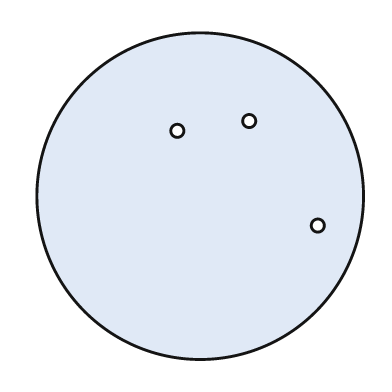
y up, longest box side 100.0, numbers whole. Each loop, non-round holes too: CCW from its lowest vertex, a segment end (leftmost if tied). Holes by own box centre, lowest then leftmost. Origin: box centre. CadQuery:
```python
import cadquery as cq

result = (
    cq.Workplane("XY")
    .moveTo(0.0, 0.0)
    .circle(50.0)
    .moveTo(36.0, -9.0)
    .circle(2.0)
    .moveTo(-7.0, 20.0)
    .circle(2.0)
    .moveTo(15.0, 23.0)
    .circle(2.0)
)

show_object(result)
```